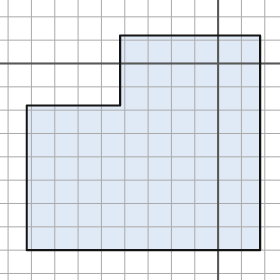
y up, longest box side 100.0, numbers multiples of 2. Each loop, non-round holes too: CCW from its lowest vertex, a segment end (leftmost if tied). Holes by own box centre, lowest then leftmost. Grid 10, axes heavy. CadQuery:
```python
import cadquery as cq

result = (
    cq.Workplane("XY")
    .moveTo(-82.0, -80.0)
    .lineTo(18.0, -80.0)
    .lineTo(18.0, 12.0)
    .lineTo(-42.0, 12.0)
    .lineTo(-42.0, -18.0)
    .lineTo(-82.0, -18.0)
    .close()
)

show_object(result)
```